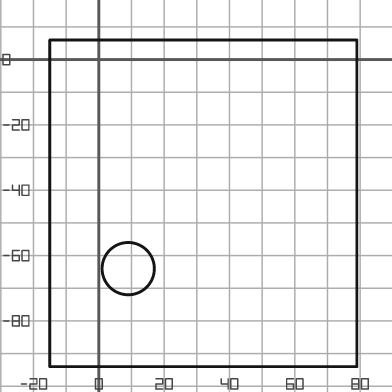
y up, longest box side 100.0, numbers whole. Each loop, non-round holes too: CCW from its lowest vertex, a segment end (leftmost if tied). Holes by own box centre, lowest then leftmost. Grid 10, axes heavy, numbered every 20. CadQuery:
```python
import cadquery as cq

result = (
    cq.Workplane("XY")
    .moveTo(-15.0, -94.0)
    .lineTo(79.0, -94.0)
    .lineTo(79.0, 6.0)
    .lineTo(-15.0, 6.0)
    .close()
    .moveTo(9.0, -64.0)
    .circle(8.0)
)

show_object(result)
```